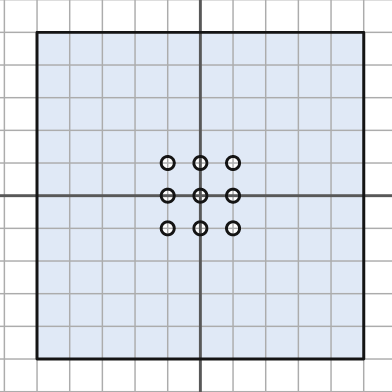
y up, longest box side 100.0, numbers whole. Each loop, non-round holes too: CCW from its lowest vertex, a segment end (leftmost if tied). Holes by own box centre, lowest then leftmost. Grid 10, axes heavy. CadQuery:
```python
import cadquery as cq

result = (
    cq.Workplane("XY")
    .moveTo(-50.0, -50.0)
    .lineTo(50.0, -50.0)
    .lineTo(50.0, 50.0)
    .lineTo(-50.0, 50.0)
    .close()
    .moveTo(-10.0, -10.0)
    .circle(2.0)
    .moveTo(0.0, -10.0)
    .circle(2.0)
    .moveTo(10.0, -10.0)
    .circle(2.0)
    .moveTo(-10.0, 0.0)
    .circle(2.0)
    .moveTo(0.0, 0.0)
    .circle(2.0)
    .moveTo(10.0, 0.0)
    .circle(2.0)
    .moveTo(-10.0, 10.0)
    .circle(2.0)
    .moveTo(0.0, 10.0)
    .circle(2.0)
    .moveTo(10.0, 10.0)
    .circle(2.0)
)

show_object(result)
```